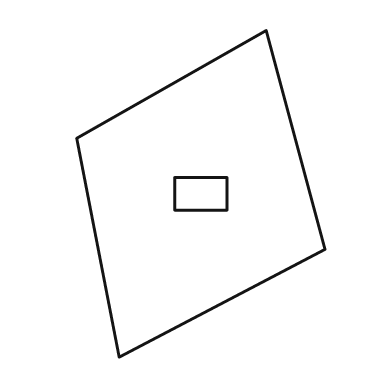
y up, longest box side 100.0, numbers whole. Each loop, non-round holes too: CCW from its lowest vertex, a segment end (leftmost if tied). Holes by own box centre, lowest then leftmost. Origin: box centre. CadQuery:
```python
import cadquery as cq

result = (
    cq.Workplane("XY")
    .moveTo(-25.0, -50.0)
    .lineTo(38.0, -17.0)
    .lineTo(20.0, 50.0)
    .lineTo(-38.0, 17.0)
    .close()
    .moveTo(-8.0, -5.0)
    .lineTo(8.0, -5.0)
    .lineTo(8.0, 5.0)
    .lineTo(-8.0, 5.0)
    .close()
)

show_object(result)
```